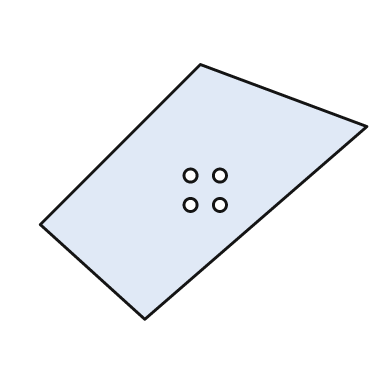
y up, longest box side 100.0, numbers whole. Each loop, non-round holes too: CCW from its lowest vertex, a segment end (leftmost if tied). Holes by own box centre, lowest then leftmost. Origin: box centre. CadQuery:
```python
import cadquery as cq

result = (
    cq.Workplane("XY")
    .moveTo(-18.0, -39.0)
    .lineTo(50.0, 20.0)
    .lineTo(-1.0, 39.0)
    .lineTo(-50.0, -10.0)
    .close()
    .moveTo(-4.0, -4.0)
    .circle(2.0)
    .moveTo(5.0, -4.0)
    .circle(2.0)
    .moveTo(-4.0, 5.0)
    .circle(2.0)
    .moveTo(5.0, 5.0)
    .circle(2.0)
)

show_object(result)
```